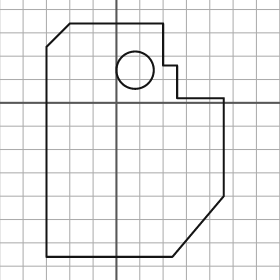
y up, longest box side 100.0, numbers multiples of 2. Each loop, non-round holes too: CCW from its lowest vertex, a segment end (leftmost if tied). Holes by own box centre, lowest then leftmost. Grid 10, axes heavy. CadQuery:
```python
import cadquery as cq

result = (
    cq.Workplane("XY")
    .moveTo(-30.0, -66.0)
    .lineTo(24.0, -66.0)
    .lineTo(46.0, -40.0)
    .lineTo(46.0, 2.0)
    .lineTo(26.0, 2.0)
    .lineTo(26.0, 16.0)
    .lineTo(20.0, 16.0)
    .lineTo(20.0, 34.0)
    .lineTo(-20.0, 34.0)
    .lineTo(-30.0, 24.0)
    .close()
    .moveTo(8.0, 14.0)
    .circle(8.0)
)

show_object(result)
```